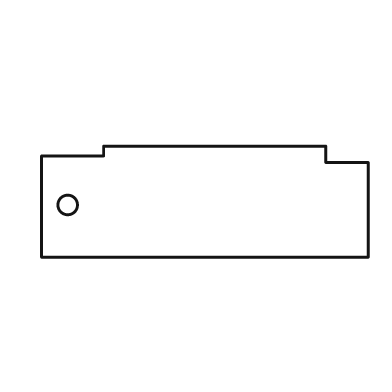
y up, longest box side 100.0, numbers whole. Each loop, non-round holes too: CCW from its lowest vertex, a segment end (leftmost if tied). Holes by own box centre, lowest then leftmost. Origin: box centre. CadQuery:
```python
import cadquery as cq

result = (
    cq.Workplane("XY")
    .moveTo(-50.0, -17.0)
    .lineTo(50.0, -17.0)
    .lineTo(50.0, 12.0)
    .lineTo(37.0, 12.0)
    .lineTo(37.0, 17.0)
    .lineTo(-31.0, 17.0)
    .lineTo(-31.0, 14.0)
    .lineTo(-50.0, 14.0)
    .close()
    .moveTo(-42.0, -1.0)
    .circle(3.0)
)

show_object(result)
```